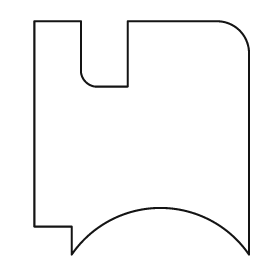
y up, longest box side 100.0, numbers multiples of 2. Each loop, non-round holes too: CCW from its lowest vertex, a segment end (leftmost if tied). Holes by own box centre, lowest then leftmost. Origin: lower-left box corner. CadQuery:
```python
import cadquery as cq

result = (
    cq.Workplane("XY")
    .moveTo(16.0, 0.0)
    .threePointArc((54.0, 20.0), (92.0, 0.0))
    .lineTo(92.0, 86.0)
    .threePointArc((88.0, 96.0), (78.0, 100.0))
    .lineTo(40.0, 100.0)
    .lineTo(40.0, 72.0)
    .lineTo(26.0, 72.0)
    .threePointArc((22.0, 74.0), (20.0, 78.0))
    .lineTo(20.0, 100.0)
    .lineTo(0.0, 100.0)
    .lineTo(0.0, 12.0)
    .lineTo(16.0, 12.0)
    .close()
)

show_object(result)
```